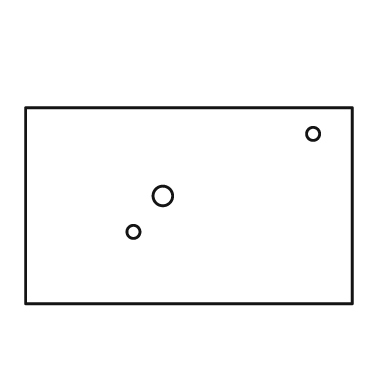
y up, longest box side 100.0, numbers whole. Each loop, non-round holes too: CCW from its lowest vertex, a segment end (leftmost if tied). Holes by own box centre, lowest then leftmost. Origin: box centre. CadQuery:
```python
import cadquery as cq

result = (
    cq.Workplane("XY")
    .moveTo(-50.0, -30.0)
    .lineTo(50.0, -30.0)
    .lineTo(50.0, 30.0)
    .lineTo(-50.0, 30.0)
    .close()
    .moveTo(-17.0, -8.0)
    .circle(2.0)
    .moveTo(-8.0, 3.0)
    .circle(3.0)
    .moveTo(38.0, 22.0)
    .circle(2.0)
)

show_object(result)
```